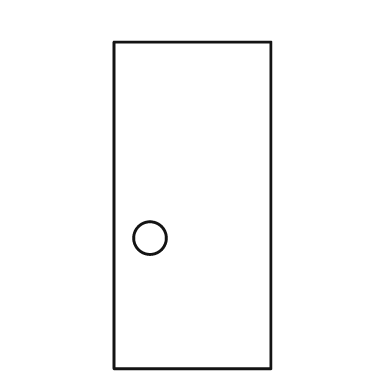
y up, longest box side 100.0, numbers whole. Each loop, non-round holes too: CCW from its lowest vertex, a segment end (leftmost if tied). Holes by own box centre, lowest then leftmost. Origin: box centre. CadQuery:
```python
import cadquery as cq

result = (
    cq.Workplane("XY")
    .moveTo(-24.0, -50.0)
    .lineTo(24.0, -50.0)
    .lineTo(24.0, 50.0)
    .lineTo(-24.0, 50.0)
    .close()
    .moveTo(-13.0, -10.0)
    .circle(5.0)
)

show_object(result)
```